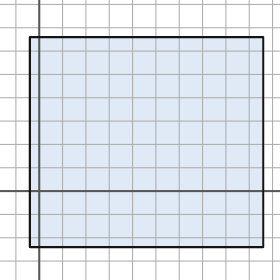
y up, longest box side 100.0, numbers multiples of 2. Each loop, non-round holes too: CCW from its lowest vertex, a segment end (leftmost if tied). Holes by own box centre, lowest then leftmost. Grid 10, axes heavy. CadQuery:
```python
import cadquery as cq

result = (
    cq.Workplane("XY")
    .moveTo(-4.0, -24.0)
    .lineTo(96.0, -24.0)
    .lineTo(96.0, 66.0)
    .lineTo(-4.0, 66.0)
    .close()
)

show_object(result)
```